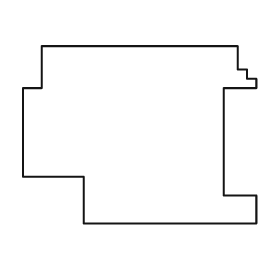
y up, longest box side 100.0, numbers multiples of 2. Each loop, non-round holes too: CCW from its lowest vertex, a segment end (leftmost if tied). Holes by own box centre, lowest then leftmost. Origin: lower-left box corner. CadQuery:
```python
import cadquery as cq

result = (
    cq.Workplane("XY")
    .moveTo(26.0, 0.0)
    .lineTo(100.0, 0.0)
    .lineTo(100.0, 12.0)
    .lineTo(86.0, 12.0)
    .lineTo(86.0, 58.0)
    .lineTo(100.0, 58.0)
    .lineTo(100.0, 62.0)
    .lineTo(96.0, 62.0)
    .lineTo(96.0, 66.0)
    .lineTo(92.0, 66.0)
    .lineTo(92.0, 76.0)
    .lineTo(8.0, 76.0)
    .lineTo(8.0, 58.0)
    .lineTo(0.0, 58.0)
    .lineTo(0.0, 20.0)
    .lineTo(26.0, 20.0)
    .close()
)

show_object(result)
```